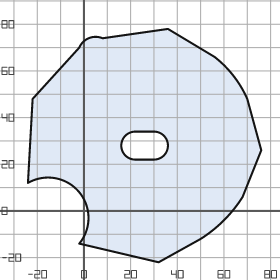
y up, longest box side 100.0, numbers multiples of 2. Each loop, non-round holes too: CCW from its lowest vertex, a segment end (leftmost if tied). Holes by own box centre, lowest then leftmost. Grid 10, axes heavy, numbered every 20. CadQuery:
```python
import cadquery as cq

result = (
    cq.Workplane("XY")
    .moveTo(32.0, -22.0)
    .lineTo(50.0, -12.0)
    .threePointArc((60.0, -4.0), (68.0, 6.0))
    .lineTo(76.0, 26.0)
    .lineTo(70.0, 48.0)
    .threePointArc((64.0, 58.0), (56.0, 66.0))
    .lineTo(36.0, 78.0)
    .lineTo(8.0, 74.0)
    .threePointArc((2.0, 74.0), (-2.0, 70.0))
    .lineTo(-22.0, 48.0)
    .lineTo(-24.0, 12.0)
    .threePointArc((-2.0, 8.0), (-2.0, -14.0))
    .close()
    .moveTo(22.0, 22.0)
    .lineTo(30.0, 22.0)
    .threePointArc((36.0, 28.0), (30.0, 34.0))
    .lineTo(22.0, 34.0)
    .threePointArc((16.0, 28.0), (22.0, 22.0))
    .close()
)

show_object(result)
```